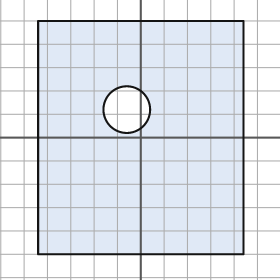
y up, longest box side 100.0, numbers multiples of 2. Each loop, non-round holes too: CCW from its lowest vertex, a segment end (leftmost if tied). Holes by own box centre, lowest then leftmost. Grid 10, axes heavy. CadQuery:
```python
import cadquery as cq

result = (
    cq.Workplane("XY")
    .moveTo(-44.0, -50.0)
    .lineTo(44.0, -50.0)
    .lineTo(44.0, 50.0)
    .lineTo(-44.0, 50.0)
    .close()
    .moveTo(-6.0, 12.0)
    .circle(10.0)
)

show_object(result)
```